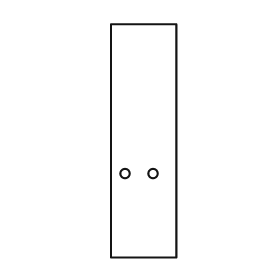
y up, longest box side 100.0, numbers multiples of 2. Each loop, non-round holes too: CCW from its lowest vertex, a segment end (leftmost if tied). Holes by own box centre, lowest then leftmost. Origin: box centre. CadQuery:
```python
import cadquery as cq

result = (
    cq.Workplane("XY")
    .moveTo(-14.0, -50.0)
    .lineTo(14.0, -50.0)
    .lineTo(14.0, 50.0)
    .lineTo(-14.0, 50.0)
    .close()
    .moveTo(-8.0, -14.0)
    .circle(2.0)
    .moveTo(4.0, -14.0)
    .circle(2.0)
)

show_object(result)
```